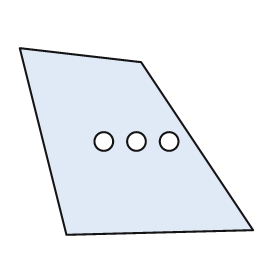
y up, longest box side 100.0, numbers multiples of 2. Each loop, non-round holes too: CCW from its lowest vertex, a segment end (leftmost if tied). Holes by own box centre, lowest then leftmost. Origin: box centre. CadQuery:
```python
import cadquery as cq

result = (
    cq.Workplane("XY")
    .moveTo(-30.0, -40.0)
    .lineTo(50.0, -38.0)
    .lineTo(2.0, 34.0)
    .lineTo(-50.0, 40.0)
    .close()
    .moveTo(-14.0, 0.0)
    .circle(4.0)
    .moveTo(0.0, 0.0)
    .circle(4.0)
    .moveTo(14.0, 0.0)
    .circle(4.0)
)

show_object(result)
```